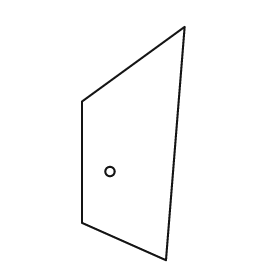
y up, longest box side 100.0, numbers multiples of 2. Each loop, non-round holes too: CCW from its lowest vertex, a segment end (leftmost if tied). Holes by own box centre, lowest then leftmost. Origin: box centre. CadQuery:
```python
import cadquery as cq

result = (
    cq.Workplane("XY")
    .moveTo(14.0, -50.0)
    .lineTo(22.0, 50.0)
    .lineTo(-22.0, 18.0)
    .lineTo(-22.0, -34.0)
    .close()
    .moveTo(-10.0, -12.0)
    .circle(2.0)
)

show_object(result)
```